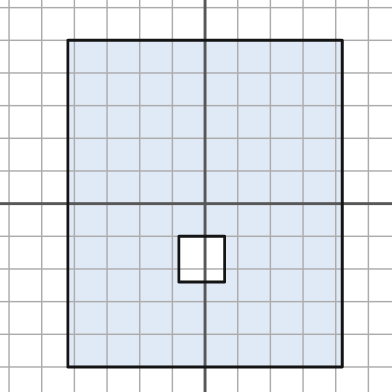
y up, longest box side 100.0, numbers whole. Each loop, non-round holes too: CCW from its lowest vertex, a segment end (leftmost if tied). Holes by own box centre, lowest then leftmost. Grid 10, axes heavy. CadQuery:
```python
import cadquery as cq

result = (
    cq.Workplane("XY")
    .moveTo(-42.0, -50.0)
    .lineTo(42.0, -50.0)
    .lineTo(42.0, 50.0)
    .lineTo(-42.0, 50.0)
    .close()
    .moveTo(-8.0, -24.0)
    .lineTo(6.0, -24.0)
    .lineTo(6.0, -10.0)
    .lineTo(-8.0, -10.0)
    .close()
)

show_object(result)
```